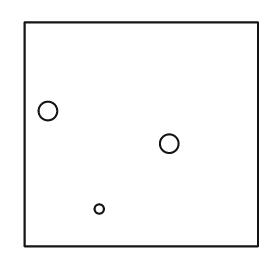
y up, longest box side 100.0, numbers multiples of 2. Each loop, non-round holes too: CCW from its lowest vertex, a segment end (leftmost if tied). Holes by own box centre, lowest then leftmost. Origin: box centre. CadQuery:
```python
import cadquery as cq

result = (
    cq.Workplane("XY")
    .moveTo(-50.0, -48.0)
    .lineTo(50.0, -48.0)
    .lineTo(50.0, 48.0)
    .lineTo(-50.0, 48.0)
    .close()
    .moveTo(-18.0, -32.0)
    .circle(2.0)
    .moveTo(12.0, -4.0)
    .circle(4.0)
    .moveTo(-40.0, 10.0)
    .circle(4.0)
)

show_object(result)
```